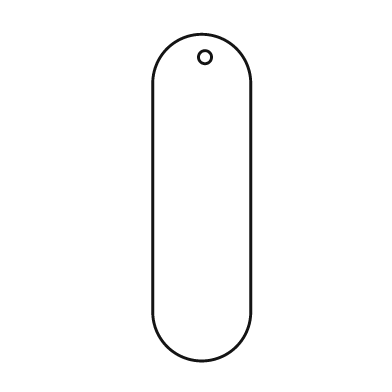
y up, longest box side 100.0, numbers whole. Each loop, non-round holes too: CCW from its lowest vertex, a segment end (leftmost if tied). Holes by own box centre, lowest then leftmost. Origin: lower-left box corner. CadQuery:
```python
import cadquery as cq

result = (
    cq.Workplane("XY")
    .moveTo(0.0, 15.0)
    .threePointArc((15.0, 0.0), (30.0, 15.0))
    .lineTo(30.0, 85.0)
    .threePointArc((15.0, 100.0), (0.0, 85.0))
    .close()
    .moveTo(16.0, 93.0)
    .circle(2.0)
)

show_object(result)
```